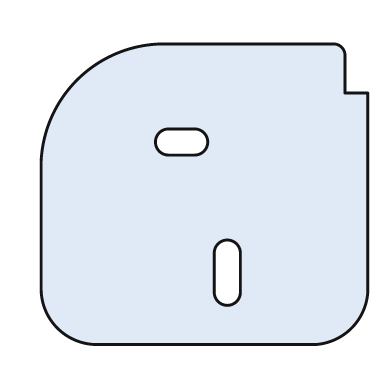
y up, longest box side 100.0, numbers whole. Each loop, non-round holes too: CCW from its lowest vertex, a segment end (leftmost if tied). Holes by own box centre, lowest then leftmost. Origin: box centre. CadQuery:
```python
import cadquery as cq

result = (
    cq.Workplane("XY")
    .moveTo(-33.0, -46.0)
    .lineTo(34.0, -46.0)
    .threePointArc((45.0, -41.0), (50.0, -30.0))
    .lineTo(50.0, 31.0)
    .lineTo(43.0, 31.0)
    .lineTo(43.0, 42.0)
    .threePointArc((42.0, 45.0), (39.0, 46.0))
    .lineTo(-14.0, 46.0)
    .threePointArc((-39.0, 35.0), (-50.0, 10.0))
    .lineTo(-50.0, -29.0)
    .threePointArc((-45.0, -41.0), (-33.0, -46.0))
    .close()
    .moveTo(3.0, -30.0)
    .threePointArc((7.0, -34.0), (11.0, -30.0))
    .lineTo(11.0, -18.0)
    .threePointArc((7.0, -14.0), (3.0, -18.0))
    .close()
    .moveTo(-11.0, 12.0)
    .lineTo(-3.0, 12.0)
    .threePointArc((1.0, 16.0), (-3.0, 20.0))
    .lineTo(-11.0, 20.0)
    .threePointArc((-15.0, 16.0), (-11.0, 12.0))
    .close()
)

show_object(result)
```